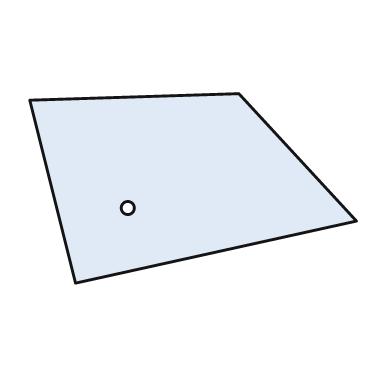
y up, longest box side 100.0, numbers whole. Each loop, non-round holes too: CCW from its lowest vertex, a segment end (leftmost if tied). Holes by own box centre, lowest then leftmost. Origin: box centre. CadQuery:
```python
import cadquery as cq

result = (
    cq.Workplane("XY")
    .moveTo(-36.0, -29.0)
    .lineTo(50.0, -10.0)
    .lineTo(14.0, 29.0)
    .lineTo(-50.0, 27.0)
    .close()
    .moveTo(-20.0, -6.0)
    .circle(2.0)
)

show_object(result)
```